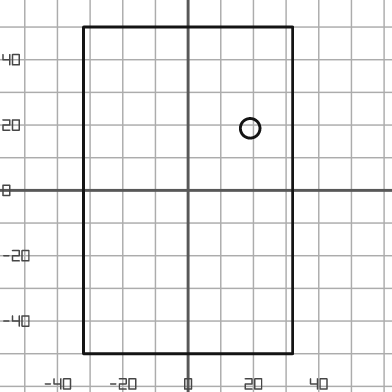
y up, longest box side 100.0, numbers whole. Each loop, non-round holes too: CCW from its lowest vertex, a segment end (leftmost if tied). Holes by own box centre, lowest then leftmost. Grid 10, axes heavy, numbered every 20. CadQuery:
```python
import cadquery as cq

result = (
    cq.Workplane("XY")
    .moveTo(-32.0, -50.0)
    .lineTo(32.0, -50.0)
    .lineTo(32.0, 50.0)
    .lineTo(-32.0, 50.0)
    .close()
    .moveTo(19.0, 19.0)
    .circle(3.0)
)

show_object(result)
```